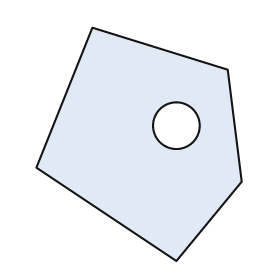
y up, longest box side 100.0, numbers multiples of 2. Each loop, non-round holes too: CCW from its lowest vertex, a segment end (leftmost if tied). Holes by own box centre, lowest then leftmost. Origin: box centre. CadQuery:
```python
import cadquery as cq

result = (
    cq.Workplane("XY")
    .moveTo(16.0, -50.0)
    .lineTo(44.0, -16.0)
    .lineTo(38.0, 32.0)
    .lineTo(-20.0, 50.0)
    .lineTo(-44.0, -10.0)
    .close()
    .moveTo(16.0, 8.0)
    .circle(10.0)
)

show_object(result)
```